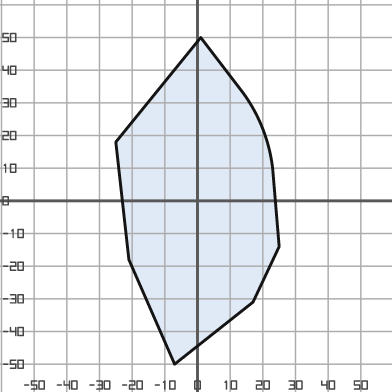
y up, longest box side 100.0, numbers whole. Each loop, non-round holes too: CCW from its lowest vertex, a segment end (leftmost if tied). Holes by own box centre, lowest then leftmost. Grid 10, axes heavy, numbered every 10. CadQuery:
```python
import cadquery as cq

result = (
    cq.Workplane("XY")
    .moveTo(-7.0, -50.0)
    .lineTo(17.0, -31.0)
    .lineTo(25.0, -14.0)
    .lineTo(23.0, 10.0)
    .threePointArc((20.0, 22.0), (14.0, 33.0))
    .lineTo(1.0, 50.0)
    .lineTo(-25.0, 18.0)
    .lineTo(-21.0, -18.0)
    .close()
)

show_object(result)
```